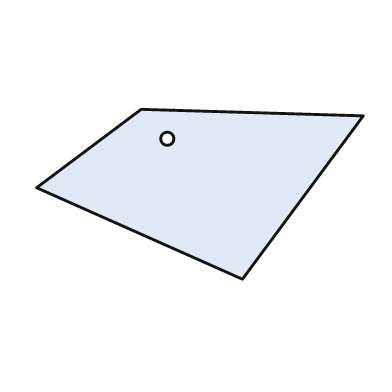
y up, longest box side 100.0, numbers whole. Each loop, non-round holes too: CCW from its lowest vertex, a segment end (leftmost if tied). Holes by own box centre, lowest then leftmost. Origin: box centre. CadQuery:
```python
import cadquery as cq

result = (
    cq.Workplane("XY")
    .moveTo(13.0, -26.0)
    .lineTo(50.0, 24.0)
    .lineTo(-18.0, 26.0)
    .lineTo(-50.0, 2.0)
    .close()
    .moveTo(-10.0, 17.0)
    .circle(2.0)
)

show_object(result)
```